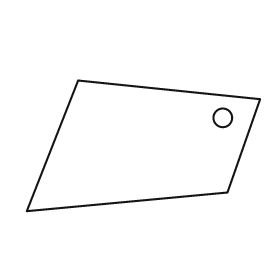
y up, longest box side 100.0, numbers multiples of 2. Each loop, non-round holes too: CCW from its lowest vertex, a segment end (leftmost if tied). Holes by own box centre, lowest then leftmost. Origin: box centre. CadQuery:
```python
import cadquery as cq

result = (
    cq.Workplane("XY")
    .moveTo(-50.0, -28.0)
    .lineTo(36.0, -20.0)
    .lineTo(50.0, 20.0)
    .lineTo(-28.0, 28.0)
    .close()
    .moveTo(34.0, 12.0)
    .circle(4.0)
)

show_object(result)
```